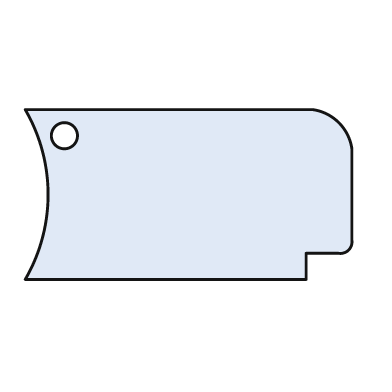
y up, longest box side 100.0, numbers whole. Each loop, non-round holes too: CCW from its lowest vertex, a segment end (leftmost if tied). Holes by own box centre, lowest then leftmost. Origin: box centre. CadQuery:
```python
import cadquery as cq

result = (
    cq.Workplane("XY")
    .moveTo(-50.0, -26.0)
    .lineTo(36.0, -26.0)
    .lineTo(36.0, -18.0)
    .lineTo(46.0, -18.0)
    .threePointArc((49.0, -17.0), (50.0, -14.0))
    .lineTo(50.0, 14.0)
    .threePointArc((46.0, 22.0), (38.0, 26.0))
    .lineTo(-50.0, 26.0)
    .threePointArc((-43.0, 0.0), (-50.0, -26.0))
    .close()
    .moveTo(-38.0, 18.0)
    .circle(4.0)
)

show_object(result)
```